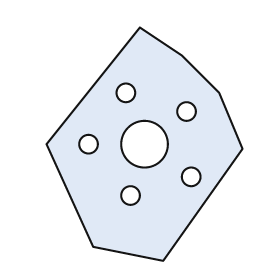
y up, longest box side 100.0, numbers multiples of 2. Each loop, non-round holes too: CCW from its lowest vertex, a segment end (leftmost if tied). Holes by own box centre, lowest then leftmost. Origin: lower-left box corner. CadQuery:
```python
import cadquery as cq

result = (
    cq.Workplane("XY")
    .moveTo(50.0, 0.0)
    .lineTo(84.0, 48.0)
    .lineTo(74.0, 72.0)
    .lineTo(58.0, 88.0)
    .lineTo(40.0, 100.0)
    .lineTo(0.0, 50.0)
    .lineTo(20.0, 6.0)
    .close()
    .moveTo(36.0, 28.0)
    .circle(4.0)
    .moveTo(62.0, 36.0)
    .circle(4.0)
    .moveTo(18.0, 50.0)
    .circle(4.0)
    .moveTo(42.0, 50.0)
    .circle(10.0)
    .moveTo(60.0, 64.0)
    .circle(4.0)
    .moveTo(34.0, 72.0)
    .circle(4.0)
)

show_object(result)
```